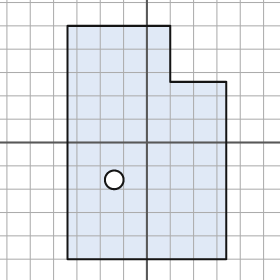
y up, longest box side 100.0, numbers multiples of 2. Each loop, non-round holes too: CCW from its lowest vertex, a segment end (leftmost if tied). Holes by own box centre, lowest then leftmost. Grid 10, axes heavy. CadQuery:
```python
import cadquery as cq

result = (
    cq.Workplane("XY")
    .moveTo(-34.0, -50.0)
    .lineTo(34.0, -50.0)
    .lineTo(34.0, 26.0)
    .lineTo(10.0, 26.0)
    .lineTo(10.0, 50.0)
    .lineTo(-34.0, 50.0)
    .close()
    .moveTo(-14.0, -16.0)
    .circle(4.0)
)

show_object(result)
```